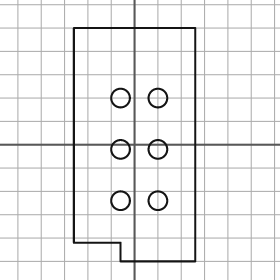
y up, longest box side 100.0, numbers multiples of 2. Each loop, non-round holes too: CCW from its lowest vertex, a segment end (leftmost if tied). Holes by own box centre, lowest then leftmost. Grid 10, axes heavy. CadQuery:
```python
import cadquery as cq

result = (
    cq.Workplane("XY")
    .moveTo(-6.0, -50.0)
    .lineTo(26.0, -50.0)
    .lineTo(26.0, 50.0)
    .lineTo(-26.0, 50.0)
    .lineTo(-26.0, -42.0)
    .lineTo(-6.0, -42.0)
    .close()
    .moveTo(-6.0, -24.0)
    .circle(4.0)
    .moveTo(10.0, -24.0)
    .circle(4.0)
    .moveTo(-6.0, -2.0)
    .circle(4.0)
    .moveTo(10.0, -2.0)
    .circle(4.0)
    .moveTo(-6.0, 20.0)
    .circle(4.0)
    .moveTo(10.0, 20.0)
    .circle(4.0)
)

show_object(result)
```